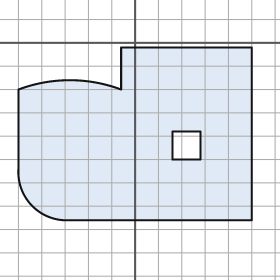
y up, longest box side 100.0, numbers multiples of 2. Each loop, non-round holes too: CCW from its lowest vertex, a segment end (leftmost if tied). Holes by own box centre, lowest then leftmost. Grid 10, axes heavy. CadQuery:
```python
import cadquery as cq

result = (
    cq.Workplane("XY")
    .moveTo(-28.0, -76.0)
    .lineTo(50.0, -76.0)
    .lineTo(50.0, -2.0)
    .lineTo(-6.0, -2.0)
    .lineTo(-6.0, -20.0)
    .threePointArc((-28.0, -16.0), (-50.0, -20.0))
    .lineTo(-50.0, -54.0)
    .threePointArc((-44.0, -70.0), (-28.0, -76.0))
    .close()
    .moveTo(16.0, -50.0)
    .lineTo(28.0, -50.0)
    .lineTo(28.0, -38.0)
    .lineTo(16.0, -38.0)
    .close()
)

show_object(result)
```